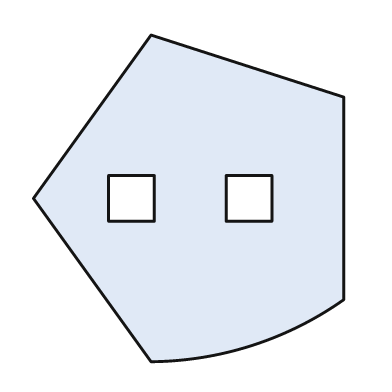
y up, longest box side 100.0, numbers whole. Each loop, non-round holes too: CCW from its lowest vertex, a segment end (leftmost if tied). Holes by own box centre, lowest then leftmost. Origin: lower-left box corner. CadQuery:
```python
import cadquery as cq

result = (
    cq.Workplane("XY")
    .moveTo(36.0, 0.0)
    .threePointArc((67.0, 5.0), (95.0, 19.0))
    .lineTo(95.0, 81.0)
    .lineTo(36.0, 100.0)
    .lineTo(0.0, 50.0)
    .close()
    .moveTo(23.0, 43.0)
    .lineTo(37.0, 43.0)
    .lineTo(37.0, 57.0)
    .lineTo(23.0, 57.0)
    .close()
    .moveTo(59.0, 43.0)
    .lineTo(73.0, 43.0)
    .lineTo(73.0, 57.0)
    .lineTo(59.0, 57.0)
    .close()
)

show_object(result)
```